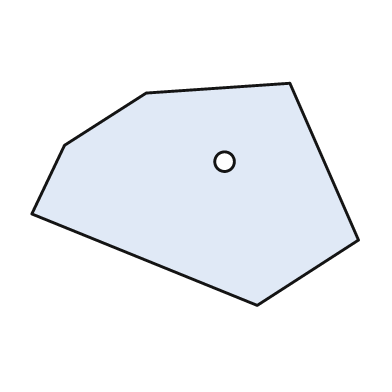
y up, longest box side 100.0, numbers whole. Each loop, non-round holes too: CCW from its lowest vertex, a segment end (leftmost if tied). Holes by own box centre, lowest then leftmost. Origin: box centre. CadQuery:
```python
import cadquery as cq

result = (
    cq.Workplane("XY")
    .moveTo(19.0, -34.0)
    .lineTo(50.0, -14.0)
    .lineTo(29.0, 34.0)
    .lineTo(-15.0, 31.0)
    .lineTo(-40.0, 15.0)
    .lineTo(-50.0, -6.0)
    .close()
    .moveTo(9.0, 10.0)
    .circle(3.0)
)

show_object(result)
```